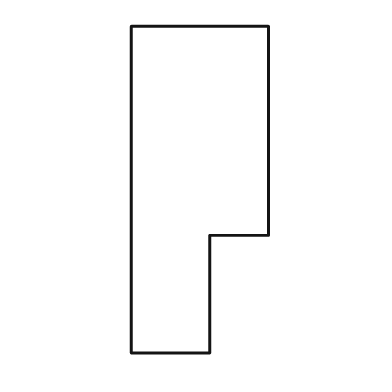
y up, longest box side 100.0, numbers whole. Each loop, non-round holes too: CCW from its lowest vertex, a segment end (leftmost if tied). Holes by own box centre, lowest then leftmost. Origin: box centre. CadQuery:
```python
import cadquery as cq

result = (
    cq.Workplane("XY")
    .moveTo(-21.0, -50.0)
    .lineTo(3.0, -50.0)
    .lineTo(3.0, -14.0)
    .lineTo(21.0, -14.0)
    .lineTo(21.0, 50.0)
    .lineTo(-21.0, 50.0)
    .close()
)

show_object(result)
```